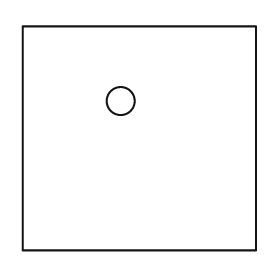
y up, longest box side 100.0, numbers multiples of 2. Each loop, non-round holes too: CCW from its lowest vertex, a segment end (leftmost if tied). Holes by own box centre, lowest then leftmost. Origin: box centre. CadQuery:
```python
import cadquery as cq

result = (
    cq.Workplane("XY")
    .moveTo(-50.0, -48.0)
    .lineTo(50.0, -48.0)
    .lineTo(50.0, 48.0)
    .lineTo(-50.0, 48.0)
    .close()
    .moveTo(-8.0, 16.0)
    .circle(6.0)
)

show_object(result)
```